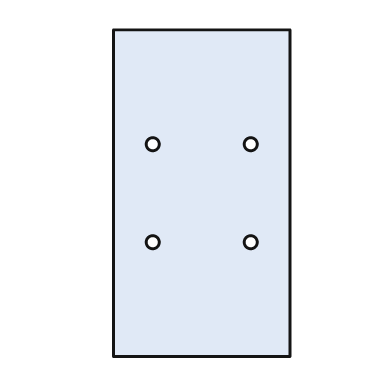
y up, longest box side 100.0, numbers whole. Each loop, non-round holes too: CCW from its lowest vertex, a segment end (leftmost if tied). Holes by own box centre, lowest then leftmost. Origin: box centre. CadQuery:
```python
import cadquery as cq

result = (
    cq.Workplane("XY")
    .moveTo(-27.0, -50.0)
    .lineTo(27.0, -50.0)
    .lineTo(27.0, 50.0)
    .lineTo(-27.0, 50.0)
    .close()
    .moveTo(-15.0, -15.0)
    .circle(2.0)
    .moveTo(15.0, -15.0)
    .circle(2.0)
    .moveTo(-15.0, 15.0)
    .circle(2.0)
    .moveTo(15.0, 15.0)
    .circle(2.0)
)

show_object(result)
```